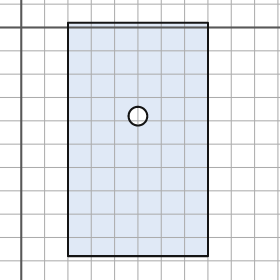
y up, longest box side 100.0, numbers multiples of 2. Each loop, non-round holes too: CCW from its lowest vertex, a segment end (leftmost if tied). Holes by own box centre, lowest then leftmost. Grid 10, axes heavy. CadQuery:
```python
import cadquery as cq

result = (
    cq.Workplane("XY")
    .moveTo(20.0, -98.0)
    .lineTo(80.0, -98.0)
    .lineTo(80.0, 2.0)
    .lineTo(20.0, 2.0)
    .close()
    .moveTo(50.0, -38.0)
    .circle(4.0)
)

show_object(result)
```